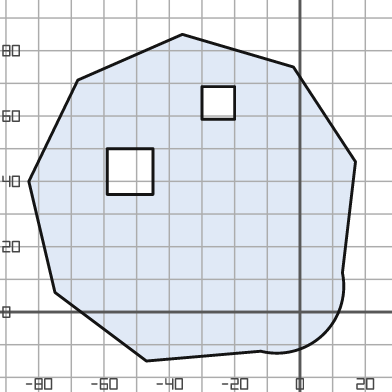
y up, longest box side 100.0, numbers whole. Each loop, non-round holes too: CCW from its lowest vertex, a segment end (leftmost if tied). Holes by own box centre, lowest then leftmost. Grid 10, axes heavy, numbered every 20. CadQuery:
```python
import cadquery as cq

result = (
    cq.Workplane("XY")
    .moveTo(-47.0, -15.0)
    .lineTo(-12.0, -12.0)
    .threePointArc((7.0, -7.0), (13.0, 12.0))
    .lineTo(17.0, 46.0)
    .lineTo(-2.0, 75.0)
    .lineTo(-36.0, 85.0)
    .lineTo(-68.0, 71.0)
    .lineTo(-83.0, 40.0)
    .lineTo(-75.0, 6.0)
    .close()
    .moveTo(-59.0, 36.0)
    .lineTo(-45.0, 36.0)
    .lineTo(-45.0, 50.0)
    .lineTo(-59.0, 50.0)
    .close()
    .moveTo(-30.0, 59.0)
    .lineTo(-20.0, 59.0)
    .lineTo(-20.0, 69.0)
    .lineTo(-30.0, 69.0)
    .close()
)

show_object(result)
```